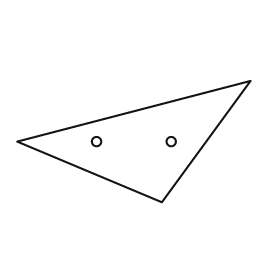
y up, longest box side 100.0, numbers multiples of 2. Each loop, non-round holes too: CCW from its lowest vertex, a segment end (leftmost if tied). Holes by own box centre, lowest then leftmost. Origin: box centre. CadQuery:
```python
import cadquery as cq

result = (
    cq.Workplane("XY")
    .moveTo(12.0, -26.0)
    .lineTo(50.0, 26.0)
    .lineTo(-50.0, 0.0)
    .close()
    .moveTo(-16.0, 0.0)
    .circle(2.0)
    .moveTo(16.0, 0.0)
    .circle(2.0)
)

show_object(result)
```